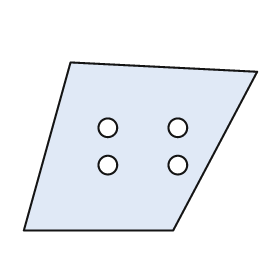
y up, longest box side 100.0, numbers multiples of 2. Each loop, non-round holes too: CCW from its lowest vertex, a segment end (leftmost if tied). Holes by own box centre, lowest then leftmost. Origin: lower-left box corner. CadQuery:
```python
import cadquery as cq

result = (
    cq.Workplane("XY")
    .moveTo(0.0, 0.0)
    .lineTo(64.0, 0.0)
    .lineTo(100.0, 68.0)
    .lineTo(20.0, 72.0)
    .close()
    .moveTo(36.0, 28.0)
    .circle(4.0)
    .moveTo(66.0, 28.0)
    .circle(4.0)
    .moveTo(36.0, 44.0)
    .circle(4.0)
    .moveTo(66.0, 44.0)
    .circle(4.0)
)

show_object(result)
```